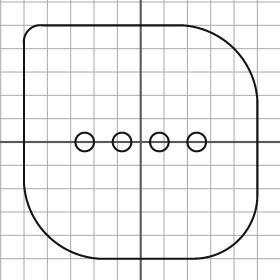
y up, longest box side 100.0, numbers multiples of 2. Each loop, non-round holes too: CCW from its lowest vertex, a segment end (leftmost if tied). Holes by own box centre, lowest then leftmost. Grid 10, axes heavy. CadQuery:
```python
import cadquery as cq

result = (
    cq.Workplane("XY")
    .moveTo(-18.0, -50.0)
    .lineTo(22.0, -50.0)
    .threePointArc((42.0, -42.0), (50.0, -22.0))
    .lineTo(50.0, 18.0)
    .threePointArc((40.0, 40.0), (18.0, 50.0))
    .lineTo(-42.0, 50.0)
    .threePointArc((-48.0, 48.0), (-50.0, 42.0))
    .lineTo(-50.0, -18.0)
    .threePointArc((-40.0, -40.0), (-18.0, -50.0))
    .close()
    .moveTo(-24.0, 0.0)
    .circle(4.0)
    .moveTo(-8.0, 0.0)
    .circle(4.0)
    .moveTo(8.0, 0.0)
    .circle(4.0)
    .moveTo(24.0, 0.0)
    .circle(4.0)
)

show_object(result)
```